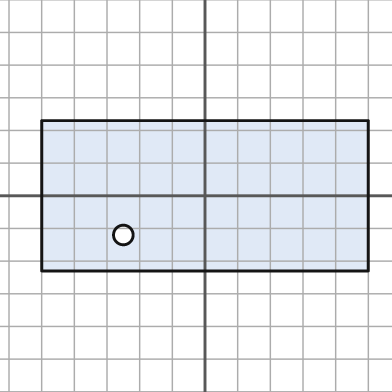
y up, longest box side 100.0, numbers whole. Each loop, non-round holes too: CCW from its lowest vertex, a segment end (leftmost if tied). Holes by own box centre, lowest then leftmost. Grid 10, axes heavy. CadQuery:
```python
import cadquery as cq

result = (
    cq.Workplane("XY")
    .moveTo(-50.0, -23.0)
    .lineTo(50.0, -23.0)
    .lineTo(50.0, 23.0)
    .lineTo(-50.0, 23.0)
    .close()
    .moveTo(-25.0, -12.0)
    .circle(3.0)
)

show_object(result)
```